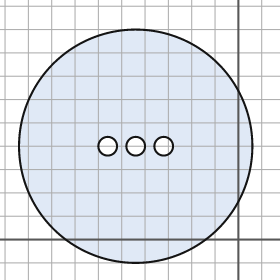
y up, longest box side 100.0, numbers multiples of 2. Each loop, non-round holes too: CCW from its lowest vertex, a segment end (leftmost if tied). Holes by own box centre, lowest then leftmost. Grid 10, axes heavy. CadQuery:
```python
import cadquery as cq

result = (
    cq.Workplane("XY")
    .moveTo(-44.0, 40.0)
    .circle(50.0)
    .moveTo(-56.0, 40.0)
    .circle(4.0)
    .moveTo(-44.0, 40.0)
    .circle(4.0)
    .moveTo(-32.0, 40.0)
    .circle(4.0)
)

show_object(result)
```